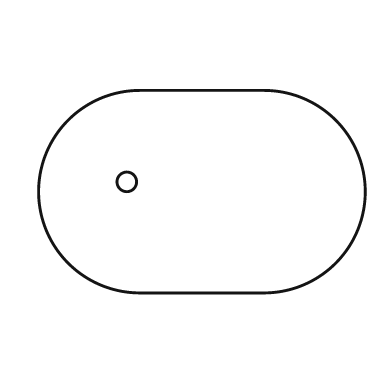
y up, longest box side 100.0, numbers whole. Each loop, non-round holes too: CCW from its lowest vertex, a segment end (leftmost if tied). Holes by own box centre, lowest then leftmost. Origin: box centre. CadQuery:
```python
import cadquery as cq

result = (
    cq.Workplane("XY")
    .moveTo(-19.0, -31.0)
    .lineTo(19.0, -31.0)
    .threePointArc((50.0, 0.0), (19.0, 31.0))
    .lineTo(-19.0, 31.0)
    .threePointArc((-50.0, 0.0), (-19.0, -31.0))
    .close()
    .moveTo(-23.0, 3.0)
    .circle(3.0)
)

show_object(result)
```